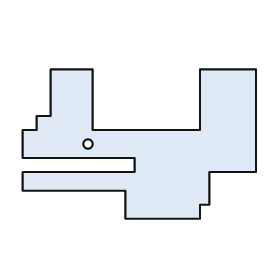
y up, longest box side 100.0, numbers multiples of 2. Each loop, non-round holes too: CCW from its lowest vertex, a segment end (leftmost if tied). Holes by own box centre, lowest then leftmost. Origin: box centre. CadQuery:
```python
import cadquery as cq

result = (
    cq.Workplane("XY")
    .moveTo(-6.0, -32.0)
    .lineTo(26.0, -32.0)
    .lineTo(26.0, -26.0)
    .lineTo(30.0, -26.0)
    .lineTo(30.0, -12.0)
    .lineTo(50.0, -12.0)
    .lineTo(50.0, 32.0)
    .lineTo(26.0, 32.0)
    .lineTo(26.0, 6.0)
    .lineTo(-20.0, 6.0)
    .lineTo(-20.0, 32.0)
    .lineTo(-38.0, 32.0)
    .lineTo(-38.0, 12.0)
    .lineTo(-44.0, 12.0)
    .lineTo(-44.0, 6.0)
    .lineTo(-50.0, 6.0)
    .lineTo(-50.0, -6.0)
    .lineTo(-2.0, -6.0)
    .lineTo(-2.0, -12.0)
    .lineTo(-50.0, -12.0)
    .lineTo(-50.0, -20.0)
    .lineTo(-6.0, -20.0)
    .close()
    .moveTo(-22.0, 0.0)
    .circle(2.0)
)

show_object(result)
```